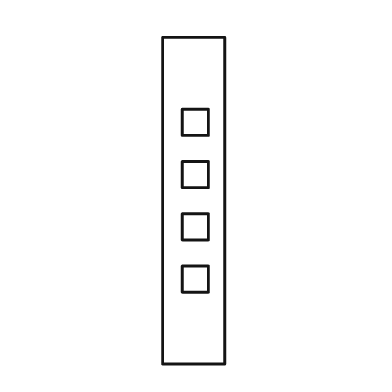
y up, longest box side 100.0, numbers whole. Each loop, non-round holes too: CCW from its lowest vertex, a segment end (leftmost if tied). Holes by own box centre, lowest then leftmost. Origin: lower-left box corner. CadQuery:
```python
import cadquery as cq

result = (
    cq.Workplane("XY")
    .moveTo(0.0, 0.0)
    .lineTo(19.0, 0.0)
    .lineTo(19.0, 100.0)
    .lineTo(0.0, 100.0)
    .close()
    .moveTo(6.0, 22.0)
    .lineTo(14.0, 22.0)
    .lineTo(14.0, 30.0)
    .lineTo(6.0, 30.0)
    .close()
    .moveTo(6.0, 38.0)
    .lineTo(14.0, 38.0)
    .lineTo(14.0, 46.0)
    .lineTo(6.0, 46.0)
    .close()
    .moveTo(6.0, 54.0)
    .lineTo(14.0, 54.0)
    .lineTo(14.0, 62.0)
    .lineTo(6.0, 62.0)
    .close()
    .moveTo(6.0, 70.0)
    .lineTo(14.0, 70.0)
    .lineTo(14.0, 78.0)
    .lineTo(6.0, 78.0)
    .close()
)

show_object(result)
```